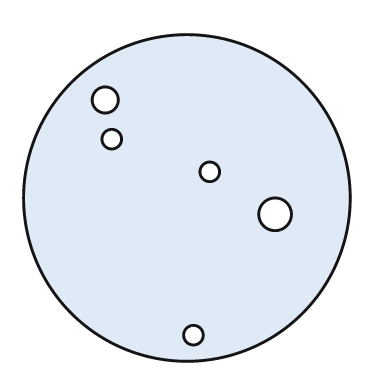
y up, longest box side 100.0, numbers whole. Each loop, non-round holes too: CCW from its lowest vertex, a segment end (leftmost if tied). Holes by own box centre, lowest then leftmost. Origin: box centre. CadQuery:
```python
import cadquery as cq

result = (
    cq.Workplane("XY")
    .moveTo(0.0, 0.0)
    .circle(50.0)
    .moveTo(2.0, -42.0)
    .circle(3.0)
    .moveTo(27.0, -5.0)
    .circle(5.0)
    .moveTo(7.0, 8.0)
    .circle(3.0)
    .moveTo(-23.0, 18.0)
    .circle(3.0)
    .moveTo(-25.0, 30.0)
    .circle(4.0)
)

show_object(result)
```